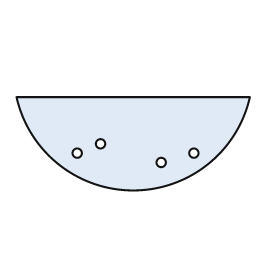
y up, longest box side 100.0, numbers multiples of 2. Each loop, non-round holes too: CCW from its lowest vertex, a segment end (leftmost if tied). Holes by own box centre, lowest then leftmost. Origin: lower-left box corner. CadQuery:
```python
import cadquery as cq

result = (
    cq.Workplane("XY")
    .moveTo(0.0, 40.0)
    .threePointArc((50.0, 0.0), (100.0, 40.0))
    .close()
    .moveTo(62.0, 12.0)
    .circle(2.0)
    .moveTo(26.0, 16.0)
    .circle(2.0)
    .moveTo(76.0, 16.0)
    .circle(2.0)
    .moveTo(36.0, 20.0)
    .circle(2.0)
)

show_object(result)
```